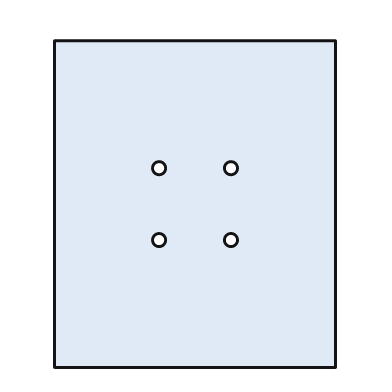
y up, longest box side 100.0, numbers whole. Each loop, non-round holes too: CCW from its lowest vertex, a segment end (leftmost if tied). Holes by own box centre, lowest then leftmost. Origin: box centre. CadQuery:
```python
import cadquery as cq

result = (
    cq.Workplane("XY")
    .moveTo(-43.0, -50.0)
    .lineTo(43.0, -50.0)
    .lineTo(43.0, 50.0)
    .lineTo(-43.0, 50.0)
    .close()
    .moveTo(-11.0, -11.0)
    .circle(2.0)
    .moveTo(11.0, -11.0)
    .circle(2.0)
    .moveTo(-11.0, 11.0)
    .circle(2.0)
    .moveTo(11.0, 11.0)
    .circle(2.0)
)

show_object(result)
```